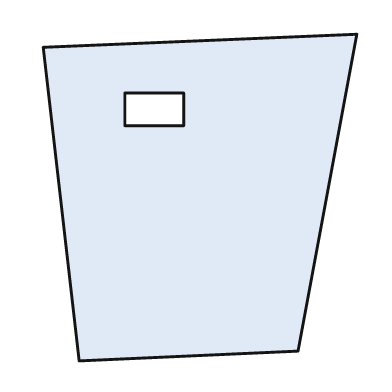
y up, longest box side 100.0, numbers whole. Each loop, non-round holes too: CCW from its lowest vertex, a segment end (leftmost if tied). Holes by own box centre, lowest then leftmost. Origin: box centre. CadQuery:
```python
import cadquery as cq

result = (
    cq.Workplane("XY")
    .moveTo(-37.0, -50.0)
    .lineTo(30.0, -47.0)
    .lineTo(48.0, 50.0)
    .lineTo(-48.0, 46.0)
    .close()
    .moveTo(-23.0, 22.0)
    .lineTo(-5.0, 22.0)
    .lineTo(-5.0, 32.0)
    .lineTo(-23.0, 32.0)
    .close()
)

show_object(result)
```